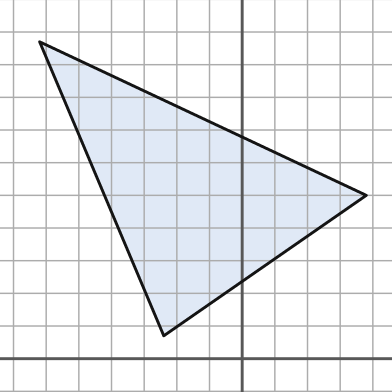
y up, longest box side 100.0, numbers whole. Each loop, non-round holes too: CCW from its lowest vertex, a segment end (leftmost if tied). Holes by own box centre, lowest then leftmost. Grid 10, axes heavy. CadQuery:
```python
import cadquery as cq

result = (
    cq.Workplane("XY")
    .moveTo(-24.0, 7.0)
    .lineTo(38.0, 50.0)
    .lineTo(-62.0, 97.0)
    .close()
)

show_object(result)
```